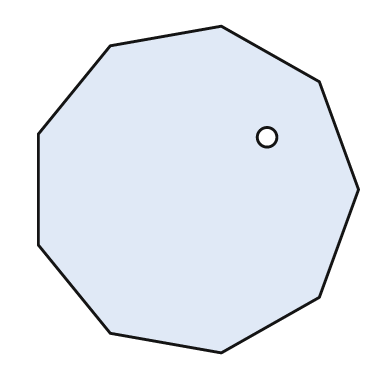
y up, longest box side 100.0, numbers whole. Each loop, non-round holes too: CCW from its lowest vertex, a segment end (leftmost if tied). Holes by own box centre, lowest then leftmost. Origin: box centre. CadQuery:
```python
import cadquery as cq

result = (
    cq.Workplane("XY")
    .moveTo(7.0, -50.0)
    .lineTo(37.0, -33.0)
    .lineTo(49.0, 0.0)
    .lineTo(37.0, 33.0)
    .lineTo(7.0, 50.0)
    .lineTo(-27.0, 44.0)
    .lineTo(-49.0, 17.0)
    .lineTo(-49.0, -17.0)
    .lineTo(-27.0, -44.0)
    .close()
    .moveTo(21.0, 16.0)
    .circle(3.0)
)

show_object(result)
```